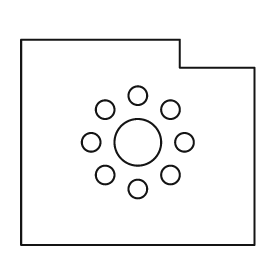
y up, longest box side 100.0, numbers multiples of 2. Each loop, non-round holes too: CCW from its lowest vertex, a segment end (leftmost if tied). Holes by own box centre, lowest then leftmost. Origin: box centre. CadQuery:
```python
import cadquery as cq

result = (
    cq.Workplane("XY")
    .moveTo(-50.0, -44.0)
    .lineTo(50.0, -44.0)
    .lineTo(50.0, 32.0)
    .lineTo(18.0, 32.0)
    .lineTo(18.0, 44.0)
    .lineTo(-50.0, 44.0)
    .close()
    .moveTo(0.0, -20.0)
    .circle(4.0)
    .moveTo(-14.0, -14.0)
    .circle(4.0)
    .moveTo(14.0, -14.0)
    .circle(4.0)
    .moveTo(-20.0, 0.0)
    .circle(4.0)
    .moveTo(0.0, 0.0)
    .circle(10.0)
    .moveTo(20.0, 0.0)
    .circle(4.0)
    .moveTo(-14.0, 14.0)
    .circle(4.0)
    .moveTo(14.0, 14.0)
    .circle(4.0)
    .moveTo(0.0, 20.0)
    .circle(4.0)
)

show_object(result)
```